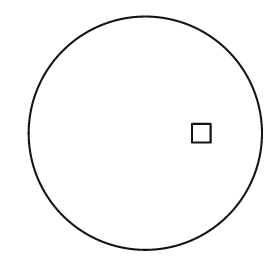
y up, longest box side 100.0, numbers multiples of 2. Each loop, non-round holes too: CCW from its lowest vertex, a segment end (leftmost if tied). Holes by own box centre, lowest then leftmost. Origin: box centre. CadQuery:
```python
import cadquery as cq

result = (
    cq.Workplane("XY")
    .moveTo(0.0, 0.0)
    .circle(50.0)
    .moveTo(20.0, -4.0)
    .lineTo(28.0, -4.0)
    .lineTo(28.0, 4.0)
    .lineTo(20.0, 4.0)
    .close()
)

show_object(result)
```